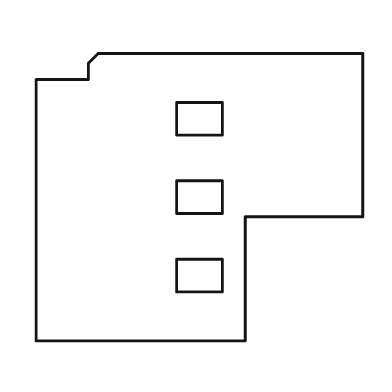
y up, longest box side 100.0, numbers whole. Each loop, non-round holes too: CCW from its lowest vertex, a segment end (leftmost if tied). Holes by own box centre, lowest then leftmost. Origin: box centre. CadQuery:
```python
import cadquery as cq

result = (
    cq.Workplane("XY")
    .moveTo(-50.0, -44.0)
    .lineTo(14.0, -44.0)
    .lineTo(14.0, -6.0)
    .lineTo(50.0, -6.0)
    .lineTo(50.0, 44.0)
    .lineTo(-31.0, 44.0)
    .lineTo(-34.0, 41.0)
    .lineTo(-34.0, 36.0)
    .lineTo(-50.0, 36.0)
    .close()
    .moveTo(-7.0, -29.0)
    .lineTo(7.0, -29.0)
    .lineTo(7.0, -19.0)
    .lineTo(-7.0, -19.0)
    .close()
    .moveTo(-7.0, -5.0)
    .lineTo(7.0, -5.0)
    .lineTo(7.0, 5.0)
    .lineTo(-7.0, 5.0)
    .close()
    .moveTo(-7.0, 19.0)
    .lineTo(7.0, 19.0)
    .lineTo(7.0, 29.0)
    .lineTo(-7.0, 29.0)
    .close()
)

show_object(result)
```